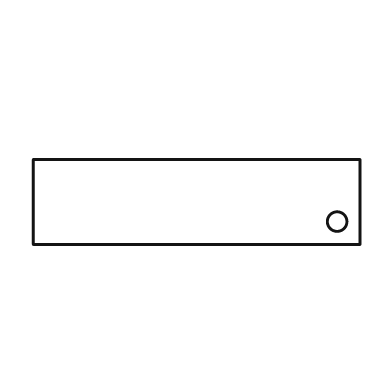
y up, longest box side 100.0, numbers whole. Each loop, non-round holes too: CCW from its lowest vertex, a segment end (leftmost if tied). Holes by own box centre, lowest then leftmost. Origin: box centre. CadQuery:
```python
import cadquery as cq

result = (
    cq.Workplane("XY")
    .moveTo(-50.0, -13.0)
    .lineTo(50.0, -13.0)
    .lineTo(50.0, 13.0)
    .lineTo(-50.0, 13.0)
    .close()
    .moveTo(43.0, -6.0)
    .circle(3.0)
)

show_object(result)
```